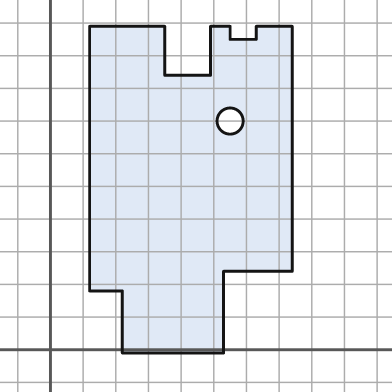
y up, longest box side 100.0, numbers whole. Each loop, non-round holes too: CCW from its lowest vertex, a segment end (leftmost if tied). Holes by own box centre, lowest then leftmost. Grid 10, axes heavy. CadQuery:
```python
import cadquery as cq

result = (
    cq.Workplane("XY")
    .moveTo(22.0, -1.0)
    .lineTo(53.0, -1.0)
    .lineTo(53.0, 24.0)
    .lineTo(74.0, 24.0)
    .lineTo(74.0, 99.0)
    .lineTo(63.0, 99.0)
    .lineTo(63.0, 95.0)
    .lineTo(55.0, 95.0)
    .lineTo(55.0, 99.0)
    .lineTo(49.0, 99.0)
    .lineTo(49.0, 84.0)
    .lineTo(35.0, 84.0)
    .lineTo(35.0, 99.0)
    .lineTo(12.0, 99.0)
    .lineTo(12.0, 18.0)
    .lineTo(22.0, 18.0)
    .close()
    .moveTo(55.0, 70.0)
    .circle(4.0)
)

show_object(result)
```